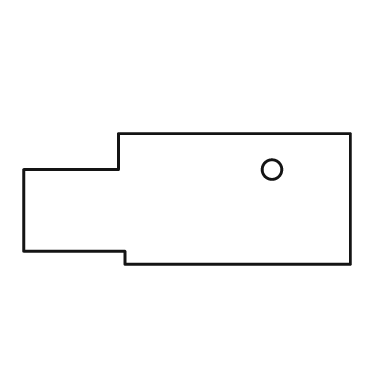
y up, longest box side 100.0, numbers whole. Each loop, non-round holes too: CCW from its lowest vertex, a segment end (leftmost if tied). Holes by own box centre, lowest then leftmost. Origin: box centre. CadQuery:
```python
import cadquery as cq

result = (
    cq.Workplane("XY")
    .moveTo(-19.0, -20.0)
    .lineTo(50.0, -20.0)
    .lineTo(50.0, 20.0)
    .lineTo(-21.0, 20.0)
    .lineTo(-21.0, 9.0)
    .lineTo(-50.0, 9.0)
    .lineTo(-50.0, -16.0)
    .lineTo(-19.0, -16.0)
    .close()
    .moveTo(26.0, 9.0)
    .circle(3.0)
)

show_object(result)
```